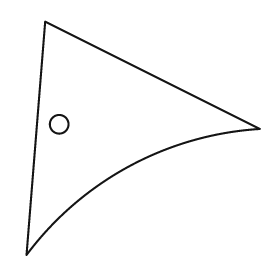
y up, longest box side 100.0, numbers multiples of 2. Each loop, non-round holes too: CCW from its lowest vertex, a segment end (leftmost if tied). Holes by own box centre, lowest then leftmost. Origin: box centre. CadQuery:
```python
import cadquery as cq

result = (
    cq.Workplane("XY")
    .moveTo(-50.0, -50.0)
    .threePointArc((-6.0, -12.0), (50.0, 4.0))
    .lineTo(-42.0, 50.0)
    .close()
    .moveTo(-36.0, 6.0)
    .circle(4.0)
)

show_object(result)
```